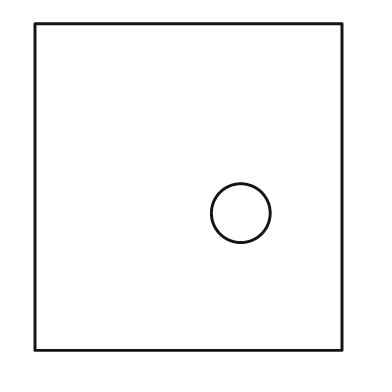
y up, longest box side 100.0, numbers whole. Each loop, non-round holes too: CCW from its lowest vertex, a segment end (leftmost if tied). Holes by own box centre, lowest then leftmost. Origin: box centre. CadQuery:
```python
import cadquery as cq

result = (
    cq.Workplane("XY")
    .moveTo(-47.0, -50.0)
    .lineTo(47.0, -50.0)
    .lineTo(47.0, 50.0)
    .lineTo(-47.0, 50.0)
    .close()
    .moveTo(16.0, -8.0)
    .circle(9.0)
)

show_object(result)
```